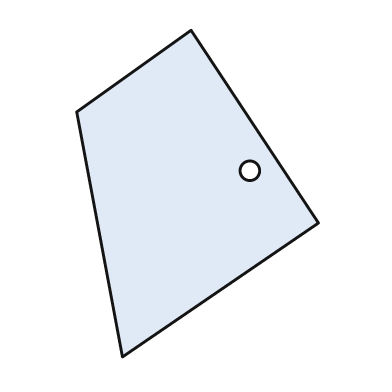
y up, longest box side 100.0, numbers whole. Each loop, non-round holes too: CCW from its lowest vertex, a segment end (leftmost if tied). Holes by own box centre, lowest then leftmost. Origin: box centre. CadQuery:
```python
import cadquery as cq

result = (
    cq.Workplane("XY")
    .moveTo(-23.0, -50.0)
    .lineTo(37.0, -9.0)
    .lineTo(-2.0, 50.0)
    .lineTo(-37.0, 25.0)
    .close()
    .moveTo(16.0, 7.0)
    .circle(3.0)
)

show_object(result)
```